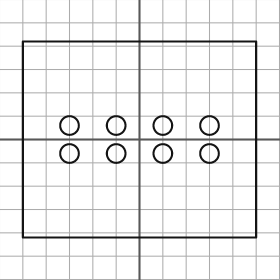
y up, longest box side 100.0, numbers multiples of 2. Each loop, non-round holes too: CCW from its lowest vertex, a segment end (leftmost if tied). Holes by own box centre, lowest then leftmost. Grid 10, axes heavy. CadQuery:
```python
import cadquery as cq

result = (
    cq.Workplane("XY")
    .moveTo(-50.0, -42.0)
    .lineTo(50.0, -42.0)
    .lineTo(50.0, 42.0)
    .lineTo(-50.0, 42.0)
    .close()
    .moveTo(-30.0, -6.0)
    .circle(4.0)
    .moveTo(-10.0, -6.0)
    .circle(4.0)
    .moveTo(10.0, -6.0)
    .circle(4.0)
    .moveTo(30.0, -6.0)
    .circle(4.0)
    .moveTo(-30.0, 6.0)
    .circle(4.0)
    .moveTo(-10.0, 6.0)
    .circle(4.0)
    .moveTo(10.0, 6.0)
    .circle(4.0)
    .moveTo(30.0, 6.0)
    .circle(4.0)
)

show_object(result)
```